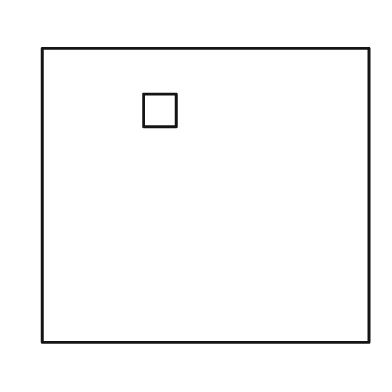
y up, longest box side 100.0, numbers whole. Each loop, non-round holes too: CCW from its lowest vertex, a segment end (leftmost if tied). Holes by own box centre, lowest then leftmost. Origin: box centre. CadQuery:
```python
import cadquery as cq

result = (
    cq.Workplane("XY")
    .moveTo(-50.0, -45.0)
    .lineTo(50.0, -45.0)
    .lineTo(50.0, 45.0)
    .lineTo(-50.0, 45.0)
    .close()
    .moveTo(-19.0, 21.0)
    .lineTo(-9.0, 21.0)
    .lineTo(-9.0, 31.0)
    .lineTo(-19.0, 31.0)
    .close()
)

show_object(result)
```